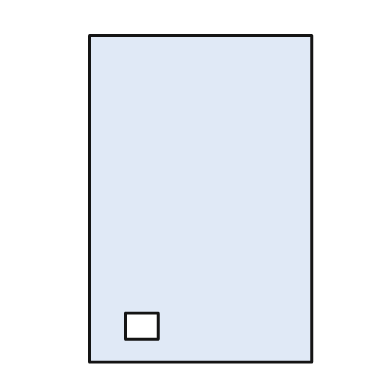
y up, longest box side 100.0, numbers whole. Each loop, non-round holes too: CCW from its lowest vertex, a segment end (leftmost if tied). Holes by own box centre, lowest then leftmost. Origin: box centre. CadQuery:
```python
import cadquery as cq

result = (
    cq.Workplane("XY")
    .moveTo(-34.0, -50.0)
    .lineTo(34.0, -50.0)
    .lineTo(34.0, 50.0)
    .lineTo(-34.0, 50.0)
    .close()
    .moveTo(-23.0, -43.0)
    .lineTo(-13.0, -43.0)
    .lineTo(-13.0, -35.0)
    .lineTo(-23.0, -35.0)
    .close()
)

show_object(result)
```